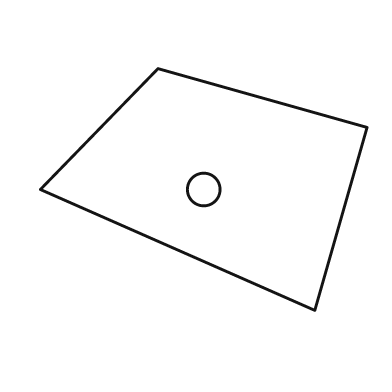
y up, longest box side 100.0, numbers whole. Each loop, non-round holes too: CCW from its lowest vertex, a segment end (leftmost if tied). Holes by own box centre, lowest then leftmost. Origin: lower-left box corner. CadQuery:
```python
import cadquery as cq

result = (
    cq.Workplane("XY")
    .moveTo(84.0, 0.0)
    .lineTo(100.0, 56.0)
    .lineTo(36.0, 74.0)
    .lineTo(0.0, 37.0)
    .close()
    .moveTo(50.0, 37.0)
    .circle(5.0)
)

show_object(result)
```